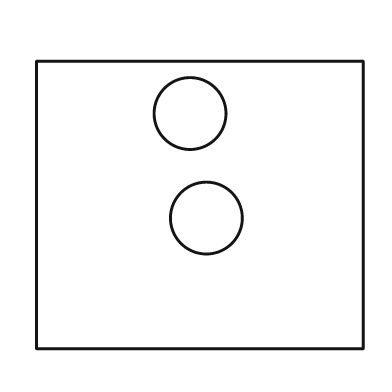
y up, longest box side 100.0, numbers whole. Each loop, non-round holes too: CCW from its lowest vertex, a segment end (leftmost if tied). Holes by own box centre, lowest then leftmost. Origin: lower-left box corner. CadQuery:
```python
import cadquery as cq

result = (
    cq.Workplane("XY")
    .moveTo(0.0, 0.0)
    .lineTo(100.0, 0.0)
    .lineTo(100.0, 88.0)
    .lineTo(0.0, 88.0)
    .close()
    .moveTo(52.0, 40.0)
    .circle(11.0)
    .moveTo(47.0, 72.0)
    .circle(11.0)
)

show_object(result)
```